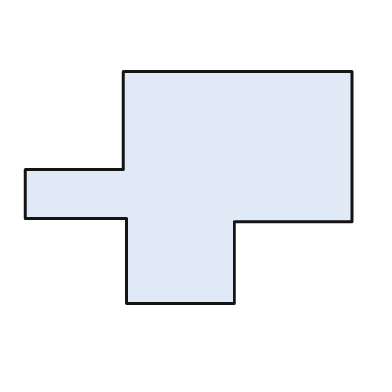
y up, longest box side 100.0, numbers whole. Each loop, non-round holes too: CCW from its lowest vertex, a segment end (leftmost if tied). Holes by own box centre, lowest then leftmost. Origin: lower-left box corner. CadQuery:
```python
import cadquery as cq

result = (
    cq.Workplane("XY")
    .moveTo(31.0, 0.0)
    .lineTo(64.0, 0.0)
    .lineTo(64.0, 25.0)
    .lineTo(100.0, 25.0)
    .lineTo(100.0, 71.0)
    .lineTo(30.0, 71.0)
    .lineTo(30.0, 41.0)
    .lineTo(0.0, 41.0)
    .lineTo(0.0, 26.0)
    .lineTo(31.0, 26.0)
    .close()
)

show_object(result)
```